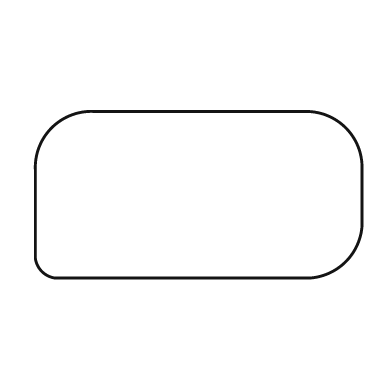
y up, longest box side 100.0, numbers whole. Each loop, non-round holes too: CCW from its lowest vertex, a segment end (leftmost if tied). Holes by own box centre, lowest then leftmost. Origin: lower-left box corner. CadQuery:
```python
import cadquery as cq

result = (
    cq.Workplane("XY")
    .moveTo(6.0, 0.0)
    .lineTo(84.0, 0.0)
    .threePointArc((95.0, 5.0), (100.0, 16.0))
    .lineTo(100.0, 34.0)
    .threePointArc((95.0, 46.0), (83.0, 51.0))
    .lineTo(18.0, 51.0)
    .threePointArc((5.0, 46.0), (0.0, 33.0))
    .lineTo(0.0, 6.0)
    .threePointArc((2.0, 2.0), (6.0, 0.0))
    .close()
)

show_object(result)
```